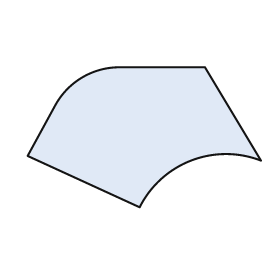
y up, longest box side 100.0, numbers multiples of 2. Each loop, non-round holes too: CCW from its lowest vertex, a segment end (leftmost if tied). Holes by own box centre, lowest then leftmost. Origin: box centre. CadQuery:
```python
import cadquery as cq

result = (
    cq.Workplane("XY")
    .moveTo(-2.0, -30.0)
    .threePointArc((20.0, -10.0), (50.0, -10.0))
    .lineTo(26.0, 30.0)
    .lineTo(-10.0, 30.0)
    .threePointArc((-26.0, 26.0), (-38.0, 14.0))
    .lineTo(-50.0, -8.0)
    .close()
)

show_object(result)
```